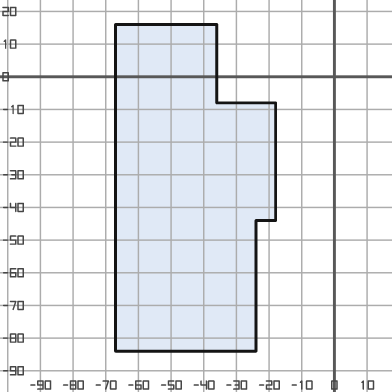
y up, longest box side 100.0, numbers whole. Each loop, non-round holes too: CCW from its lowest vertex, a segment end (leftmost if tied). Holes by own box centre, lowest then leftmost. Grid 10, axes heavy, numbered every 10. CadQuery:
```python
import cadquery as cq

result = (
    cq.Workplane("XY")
    .moveTo(-67.0, -84.0)
    .lineTo(-24.0, -84.0)
    .lineTo(-24.0, -44.0)
    .lineTo(-18.0, -44.0)
    .lineTo(-18.0, -8.0)
    .lineTo(-36.0, -8.0)
    .lineTo(-36.0, 16.0)
    .lineTo(-67.0, 16.0)
    .close()
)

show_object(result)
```